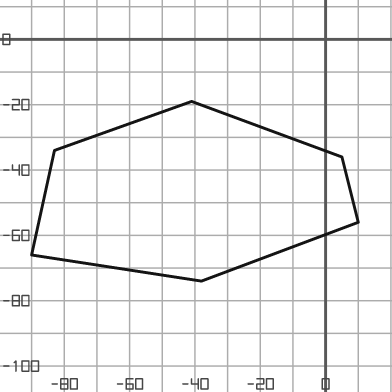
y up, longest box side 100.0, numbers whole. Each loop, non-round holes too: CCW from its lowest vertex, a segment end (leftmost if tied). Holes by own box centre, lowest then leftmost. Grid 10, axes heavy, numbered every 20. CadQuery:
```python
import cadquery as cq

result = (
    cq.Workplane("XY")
    .moveTo(-38.0, -74.0)
    .lineTo(10.0, -56.0)
    .lineTo(5.0, -36.0)
    .lineTo(-41.0, -19.0)
    .lineTo(-83.0, -34.0)
    .lineTo(-90.0, -66.0)
    .close()
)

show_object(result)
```